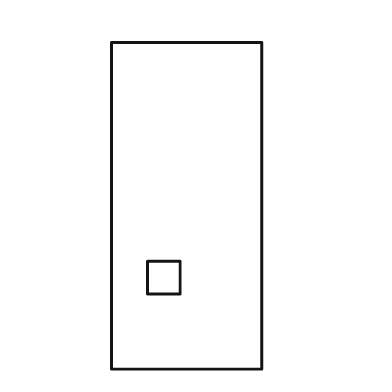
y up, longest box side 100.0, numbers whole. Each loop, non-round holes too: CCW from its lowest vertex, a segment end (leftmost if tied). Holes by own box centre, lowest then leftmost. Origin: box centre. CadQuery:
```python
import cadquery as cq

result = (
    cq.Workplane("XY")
    .moveTo(-23.0, -50.0)
    .lineTo(23.0, -50.0)
    .lineTo(23.0, 50.0)
    .lineTo(-23.0, 50.0)
    .close()
    .moveTo(-12.0, -27.0)
    .lineTo(-2.0, -27.0)
    .lineTo(-2.0, -17.0)
    .lineTo(-12.0, -17.0)
    .close()
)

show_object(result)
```